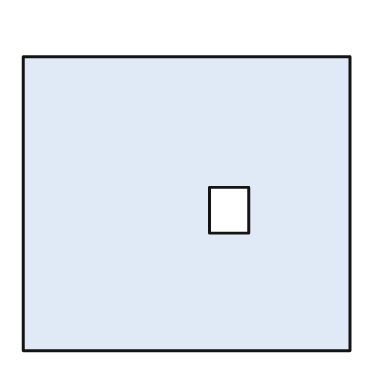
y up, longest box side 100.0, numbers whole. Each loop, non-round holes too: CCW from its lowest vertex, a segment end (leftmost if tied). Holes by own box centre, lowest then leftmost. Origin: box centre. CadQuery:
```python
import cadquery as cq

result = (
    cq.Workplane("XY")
    .moveTo(-50.0, -45.0)
    .lineTo(50.0, -45.0)
    .lineTo(50.0, 45.0)
    .lineTo(-50.0, 45.0)
    .close()
    .moveTo(7.0, -9.0)
    .lineTo(19.0, -9.0)
    .lineTo(19.0, 5.0)
    .lineTo(7.0, 5.0)
    .close()
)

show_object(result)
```